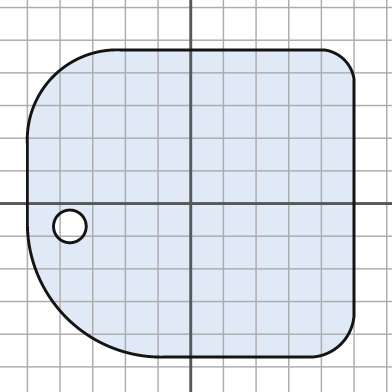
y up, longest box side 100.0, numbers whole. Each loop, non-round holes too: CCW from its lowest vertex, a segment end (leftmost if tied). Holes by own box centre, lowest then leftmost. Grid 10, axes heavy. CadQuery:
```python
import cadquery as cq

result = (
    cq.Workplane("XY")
    .moveTo(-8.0, -47.0)
    .lineTo(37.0, -47.0)
    .threePointArc((46.0, -43.0), (50.0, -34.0))
    .lineTo(50.0, 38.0)
    .threePointArc((47.0, 44.0), (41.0, 47.0))
    .lineTo(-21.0, 47.0)
    .threePointArc((-42.0, 39.0), (-50.0, 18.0))
    .lineTo(-50.0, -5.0)
    .threePointArc((-38.0, -35.0), (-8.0, -47.0))
    .close()
    .moveTo(-37.0, -7.0)
    .circle(5.0)
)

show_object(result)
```